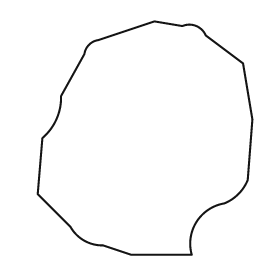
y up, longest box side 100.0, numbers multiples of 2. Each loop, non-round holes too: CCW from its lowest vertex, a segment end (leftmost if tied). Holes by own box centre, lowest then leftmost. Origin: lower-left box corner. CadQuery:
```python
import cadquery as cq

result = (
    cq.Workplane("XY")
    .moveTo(40.0, 0.0)
    .lineTo(66.0, 0.0)
    .threePointArc((68.0, 14.0), (80.0, 22.0))
    .threePointArc((86.0, 26.0), (90.0, 32.0))
    .lineTo(92.0, 58.0)
    .lineTo(88.0, 82.0)
    .lineTo(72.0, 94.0)
    .threePointArc((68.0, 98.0), (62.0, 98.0))
    .lineTo(50.0, 100.0)
    .lineTo(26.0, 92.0)
    .threePointArc((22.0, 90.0), (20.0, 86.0))
    .lineTo(10.0, 68.0)
    .threePointArc((8.0, 58.0), (2.0, 50.0))
    .lineTo(0.0, 26.0)
    .lineTo(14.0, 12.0)
    .threePointArc((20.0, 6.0), (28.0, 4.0))
    .close()
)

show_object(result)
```